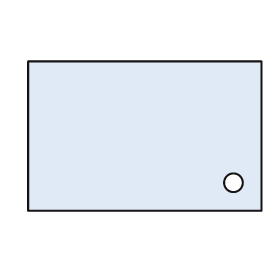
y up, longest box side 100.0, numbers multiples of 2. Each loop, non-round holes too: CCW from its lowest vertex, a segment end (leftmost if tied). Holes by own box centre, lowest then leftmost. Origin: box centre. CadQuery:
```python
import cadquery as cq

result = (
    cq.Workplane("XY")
    .moveTo(-50.0, -32.0)
    .lineTo(50.0, -32.0)
    .lineTo(50.0, 32.0)
    .lineTo(-50.0, 32.0)
    .close()
    .moveTo(38.0, -20.0)
    .circle(4.0)
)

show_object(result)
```